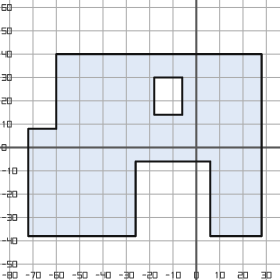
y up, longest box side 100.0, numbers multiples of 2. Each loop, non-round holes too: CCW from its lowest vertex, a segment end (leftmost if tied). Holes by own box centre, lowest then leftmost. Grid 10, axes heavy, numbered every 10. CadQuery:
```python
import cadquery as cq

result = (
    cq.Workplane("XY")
    .moveTo(-72.0, -38.0)
    .lineTo(-26.0, -38.0)
    .lineTo(-26.0, -6.0)
    .lineTo(6.0, -6.0)
    .lineTo(6.0, -38.0)
    .lineTo(28.0, -38.0)
    .lineTo(28.0, 40.0)
    .lineTo(-60.0, 40.0)
    .lineTo(-60.0, 8.0)
    .lineTo(-72.0, 8.0)
    .close()
    .moveTo(-18.0, 14.0)
    .lineTo(-6.0, 14.0)
    .lineTo(-6.0, 30.0)
    .lineTo(-18.0, 30.0)
    .close()
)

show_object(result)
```